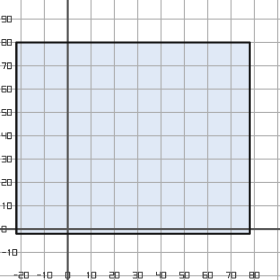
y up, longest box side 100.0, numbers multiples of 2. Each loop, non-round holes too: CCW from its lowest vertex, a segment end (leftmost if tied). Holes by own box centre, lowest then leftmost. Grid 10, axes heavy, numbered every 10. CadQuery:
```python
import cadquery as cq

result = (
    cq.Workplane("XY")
    .moveTo(-22.0, -2.0)
    .lineTo(78.0, -2.0)
    .lineTo(78.0, 80.0)
    .lineTo(-22.0, 80.0)
    .close()
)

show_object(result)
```